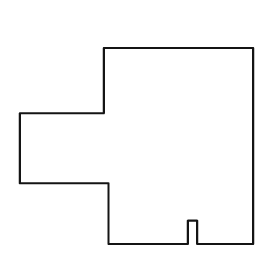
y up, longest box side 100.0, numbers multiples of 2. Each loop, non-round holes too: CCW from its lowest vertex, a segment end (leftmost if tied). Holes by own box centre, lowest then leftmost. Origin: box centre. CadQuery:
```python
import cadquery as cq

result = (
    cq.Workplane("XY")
    .moveTo(-12.0, -42.0)
    .lineTo(22.0, -42.0)
    .lineTo(22.0, -32.0)
    .lineTo(26.0, -32.0)
    .lineTo(26.0, -42.0)
    .lineTo(50.0, -42.0)
    .lineTo(50.0, 42.0)
    .lineTo(-14.0, 42.0)
    .lineTo(-14.0, 14.0)
    .lineTo(-50.0, 14.0)
    .lineTo(-50.0, -16.0)
    .lineTo(-12.0, -16.0)
    .close()
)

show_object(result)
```